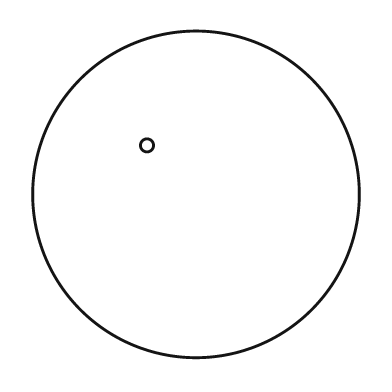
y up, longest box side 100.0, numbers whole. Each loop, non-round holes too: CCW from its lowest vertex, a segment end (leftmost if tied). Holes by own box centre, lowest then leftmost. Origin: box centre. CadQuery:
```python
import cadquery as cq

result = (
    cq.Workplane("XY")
    .moveTo(0.0, 0.0)
    .circle(50.0)
    .moveTo(-15.0, 15.0)
    .circle(2.0)
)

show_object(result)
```